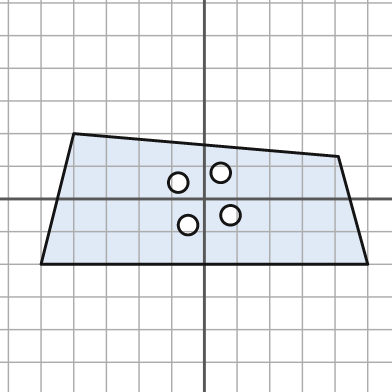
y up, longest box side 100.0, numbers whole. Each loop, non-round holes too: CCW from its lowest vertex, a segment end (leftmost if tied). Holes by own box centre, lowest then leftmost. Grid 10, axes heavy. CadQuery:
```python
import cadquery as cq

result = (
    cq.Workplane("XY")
    .moveTo(-50.0, -20.0)
    .lineTo(50.0, -20.0)
    .lineTo(41.0, 13.0)
    .lineTo(-40.0, 20.0)
    .close()
    .moveTo(-5.0, -8.0)
    .circle(3.0)
    .moveTo(8.0, -5.0)
    .circle(3.0)
    .moveTo(-8.0, 5.0)
    .circle(3.0)
    .moveTo(5.0, 8.0)
    .circle(3.0)
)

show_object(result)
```